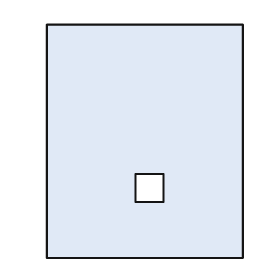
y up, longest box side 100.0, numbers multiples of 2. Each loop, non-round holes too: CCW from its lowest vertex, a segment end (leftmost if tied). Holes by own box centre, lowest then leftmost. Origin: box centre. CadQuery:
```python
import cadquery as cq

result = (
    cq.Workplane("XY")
    .moveTo(-42.0, -50.0)
    .lineTo(42.0, -50.0)
    .lineTo(42.0, 50.0)
    .lineTo(-42.0, 50.0)
    .close()
    .moveTo(-4.0, -26.0)
    .lineTo(8.0, -26.0)
    .lineTo(8.0, -14.0)
    .lineTo(-4.0, -14.0)
    .close()
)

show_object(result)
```